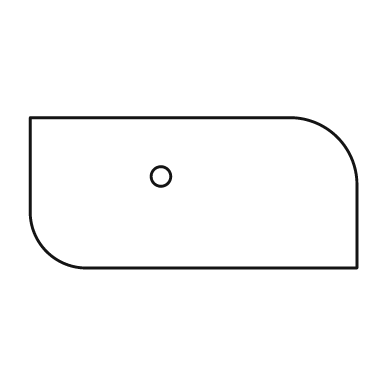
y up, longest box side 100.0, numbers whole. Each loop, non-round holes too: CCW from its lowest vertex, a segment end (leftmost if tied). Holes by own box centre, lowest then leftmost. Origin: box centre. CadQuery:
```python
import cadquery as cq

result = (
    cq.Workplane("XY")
    .moveTo(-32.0, -23.0)
    .lineTo(50.0, -23.0)
    .lineTo(50.0, 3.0)
    .threePointArc((44.0, 17.0), (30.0, 23.0))
    .lineTo(-50.0, 23.0)
    .lineTo(-50.0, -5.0)
    .threePointArc((-45.0, -18.0), (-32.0, -23.0))
    .close()
    .moveTo(-10.0, 5.0)
    .circle(3.0)
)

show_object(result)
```